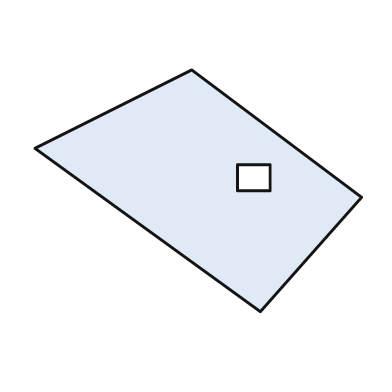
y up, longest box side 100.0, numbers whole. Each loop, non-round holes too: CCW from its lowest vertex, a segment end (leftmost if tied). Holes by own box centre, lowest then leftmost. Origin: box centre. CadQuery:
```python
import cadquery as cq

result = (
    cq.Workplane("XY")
    .moveTo(19.0, -37.0)
    .lineTo(50.0, -2.0)
    .lineTo(-2.0, 37.0)
    .lineTo(-50.0, 13.0)
    .close()
    .moveTo(12.0, 0.0)
    .lineTo(22.0, 0.0)
    .lineTo(22.0, 8.0)
    .lineTo(12.0, 8.0)
    .close()
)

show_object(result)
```